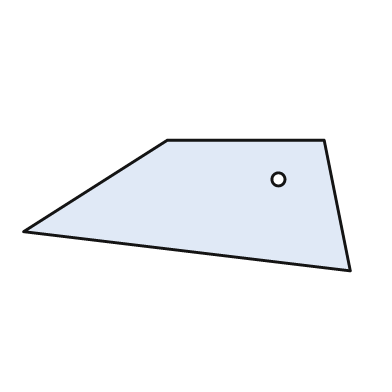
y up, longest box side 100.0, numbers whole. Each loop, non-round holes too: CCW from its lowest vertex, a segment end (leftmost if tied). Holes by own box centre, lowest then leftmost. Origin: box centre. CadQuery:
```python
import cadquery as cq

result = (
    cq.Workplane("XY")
    .moveTo(50.0, -20.0)
    .lineTo(42.0, 20.0)
    .lineTo(-6.0, 20.0)
    .lineTo(-50.0, -8.0)
    .close()
    .moveTo(28.0, 8.0)
    .circle(2.0)
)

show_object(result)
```